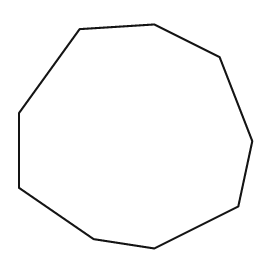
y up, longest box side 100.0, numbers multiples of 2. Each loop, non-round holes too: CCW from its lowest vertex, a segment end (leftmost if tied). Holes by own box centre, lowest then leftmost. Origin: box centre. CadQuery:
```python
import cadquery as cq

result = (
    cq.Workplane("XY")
    .moveTo(8.0, -48.0)
    .lineTo(44.0, -30.0)
    .lineTo(50.0, -2.0)
    .lineTo(36.0, 34.0)
    .lineTo(8.0, 48.0)
    .lineTo(-24.0, 46.0)
    .lineTo(-50.0, 10.0)
    .lineTo(-50.0, -22.0)
    .lineTo(-18.0, -44.0)
    .close()
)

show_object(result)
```